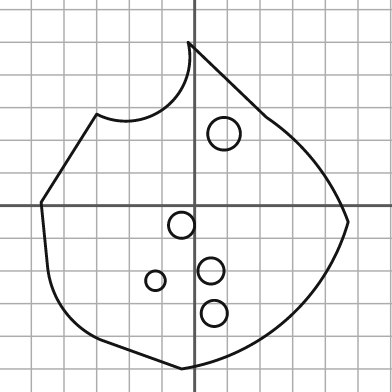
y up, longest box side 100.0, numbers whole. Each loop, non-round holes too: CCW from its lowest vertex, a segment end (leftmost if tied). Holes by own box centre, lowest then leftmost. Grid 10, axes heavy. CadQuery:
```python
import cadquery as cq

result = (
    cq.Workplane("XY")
    .moveTo(-4.0, -50.0)
    .threePointArc((28.0, -35.0), (47.0, -5.0))
    .threePointArc((37.0, 13.0), (22.0, 27.0))
    .lineTo(-2.0, 50.0)
    .threePointArc((-9.0, 30.0), (-30.0, 28.0))
    .lineTo(-47.0, 1.0)
    .lineTo(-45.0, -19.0)
    .threePointArc((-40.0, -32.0), (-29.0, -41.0))
    .close()
    .moveTo(6.0, -33.0)
    .circle(4.0)
    .moveTo(-12.0, -23.0)
    .circle(3.0)
    .moveTo(5.0, -20.0)
    .circle(4.0)
    .moveTo(-4.0, -6.0)
    .circle(4.0)
    .moveTo(9.0, 22.0)
    .circle(5.0)
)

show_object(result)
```